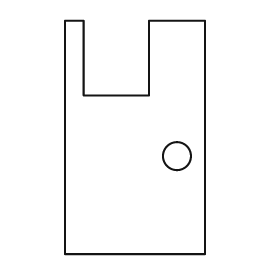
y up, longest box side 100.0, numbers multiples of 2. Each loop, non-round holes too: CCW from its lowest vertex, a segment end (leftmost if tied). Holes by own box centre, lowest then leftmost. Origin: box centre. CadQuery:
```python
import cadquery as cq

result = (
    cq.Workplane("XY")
    .moveTo(-30.0, -50.0)
    .lineTo(30.0, -50.0)
    .lineTo(30.0, 50.0)
    .lineTo(6.0, 50.0)
    .lineTo(6.0, 18.0)
    .lineTo(-22.0, 18.0)
    .lineTo(-22.0, 50.0)
    .lineTo(-30.0, 50.0)
    .close()
    .moveTo(18.0, -8.0)
    .circle(6.0)
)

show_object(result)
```